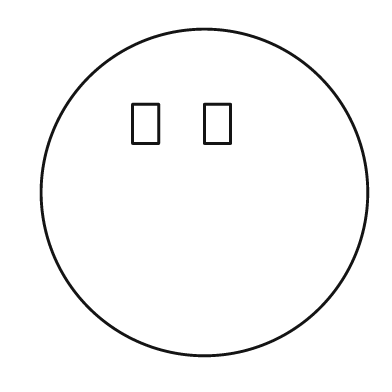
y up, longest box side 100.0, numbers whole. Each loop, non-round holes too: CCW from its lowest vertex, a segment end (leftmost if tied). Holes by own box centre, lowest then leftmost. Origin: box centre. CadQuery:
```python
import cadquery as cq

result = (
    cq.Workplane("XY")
    .moveTo(0.0, 0.0)
    .circle(50.0)
    .moveTo(-22.0, 15.0)
    .lineTo(-14.0, 15.0)
    .lineTo(-14.0, 27.0)
    .lineTo(-22.0, 27.0)
    .close()
    .moveTo(0.0, 15.0)
    .lineTo(8.0, 15.0)
    .lineTo(8.0, 27.0)
    .lineTo(0.0, 27.0)
    .close()
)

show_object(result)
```